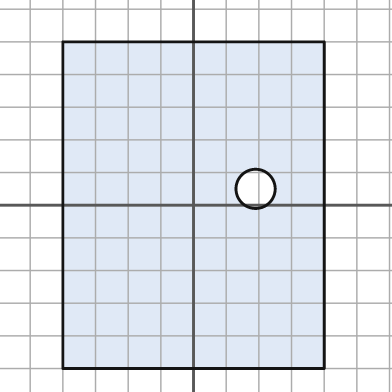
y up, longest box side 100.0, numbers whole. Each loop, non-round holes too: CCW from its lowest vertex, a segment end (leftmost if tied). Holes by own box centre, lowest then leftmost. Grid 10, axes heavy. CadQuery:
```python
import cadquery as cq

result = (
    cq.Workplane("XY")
    .moveTo(-40.0, -50.0)
    .lineTo(40.0, -50.0)
    .lineTo(40.0, 50.0)
    .lineTo(-40.0, 50.0)
    .close()
    .moveTo(19.0, 5.0)
    .circle(6.0)
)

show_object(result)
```